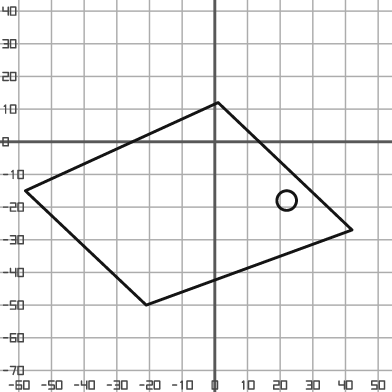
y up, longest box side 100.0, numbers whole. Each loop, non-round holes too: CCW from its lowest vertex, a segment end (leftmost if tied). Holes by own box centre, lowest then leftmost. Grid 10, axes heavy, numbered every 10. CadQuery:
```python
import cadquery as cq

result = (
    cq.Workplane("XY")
    .moveTo(-21.0, -50.0)
    .lineTo(42.0, -27.0)
    .lineTo(1.0, 12.0)
    .lineTo(-58.0, -15.0)
    .close()
    .moveTo(22.0, -18.0)
    .circle(3.0)
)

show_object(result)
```